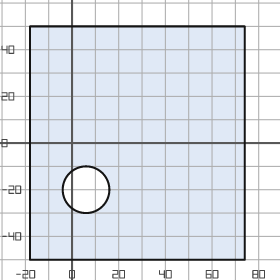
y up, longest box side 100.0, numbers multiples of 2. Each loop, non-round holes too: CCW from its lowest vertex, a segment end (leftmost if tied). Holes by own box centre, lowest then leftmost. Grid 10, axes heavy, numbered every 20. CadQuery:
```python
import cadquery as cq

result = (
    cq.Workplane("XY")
    .moveTo(-18.0, -50.0)
    .lineTo(74.0, -50.0)
    .lineTo(74.0, 50.0)
    .lineTo(-18.0, 50.0)
    .close()
    .moveTo(6.0, -20.0)
    .circle(10.0)
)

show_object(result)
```